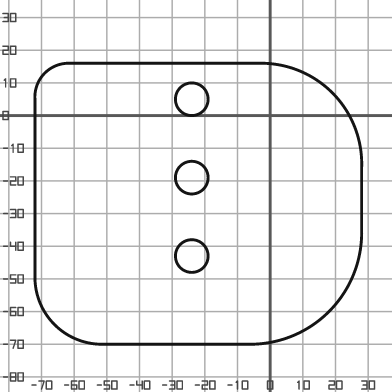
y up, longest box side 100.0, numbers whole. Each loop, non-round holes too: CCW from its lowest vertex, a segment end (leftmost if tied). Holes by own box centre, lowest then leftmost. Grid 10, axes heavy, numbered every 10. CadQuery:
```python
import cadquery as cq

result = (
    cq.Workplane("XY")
    .moveTo(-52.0, -70.0)
    .lineTo(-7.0, -70.0)
    .threePointArc((18.0, -60.0), (28.0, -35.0))
    .lineTo(28.0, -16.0)
    .threePointArc((19.0, 7.0), (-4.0, 16.0))
    .lineTo(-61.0, 16.0)
    .threePointArc((-69.0, 13.0), (-72.0, 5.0))
    .lineTo(-72.0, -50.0)
    .threePointArc((-66.0, -64.0), (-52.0, -70.0))
    .close()
    .moveTo(-24.0, -43.0)
    .circle(5.0)
    .moveTo(-24.0, -19.0)
    .circle(5.0)
    .moveTo(-24.0, 5.0)
    .circle(5.0)
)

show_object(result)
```